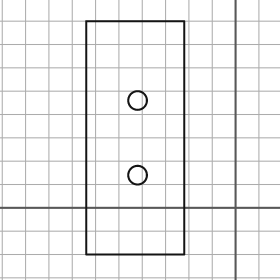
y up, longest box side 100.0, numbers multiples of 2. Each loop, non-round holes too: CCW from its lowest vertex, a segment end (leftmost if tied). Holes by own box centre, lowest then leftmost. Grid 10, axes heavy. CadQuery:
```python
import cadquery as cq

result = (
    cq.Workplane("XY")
    .moveTo(-64.0, -20.0)
    .lineTo(-22.0, -20.0)
    .lineTo(-22.0, 80.0)
    .lineTo(-64.0, 80.0)
    .close()
    .moveTo(-42.0, 14.0)
    .circle(4.0)
    .moveTo(-42.0, 46.0)
    .circle(4.0)
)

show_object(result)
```